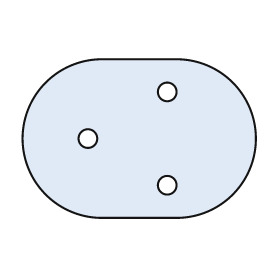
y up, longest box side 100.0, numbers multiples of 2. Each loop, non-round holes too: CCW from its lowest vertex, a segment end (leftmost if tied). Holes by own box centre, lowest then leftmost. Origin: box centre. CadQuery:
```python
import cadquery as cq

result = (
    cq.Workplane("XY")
    .moveTo(-16.0, -34.0)
    .lineTo(16.0, -34.0)
    .threePointArc((50.0, 0.0), (16.0, 34.0))
    .lineTo(-16.0, 34.0)
    .threePointArc((-50.0, 0.0), (-16.0, -34.0))
    .close()
    .moveTo(12.0, -20.0)
    .circle(4.0)
    .moveTo(-22.0, 0.0)
    .circle(4.0)
    .moveTo(12.0, 20.0)
    .circle(4.0)
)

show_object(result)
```